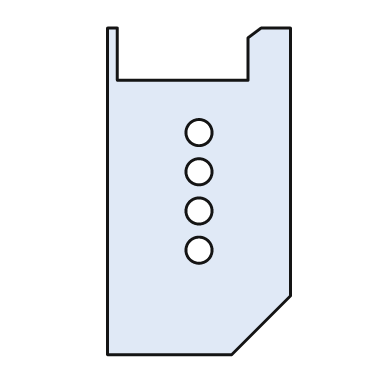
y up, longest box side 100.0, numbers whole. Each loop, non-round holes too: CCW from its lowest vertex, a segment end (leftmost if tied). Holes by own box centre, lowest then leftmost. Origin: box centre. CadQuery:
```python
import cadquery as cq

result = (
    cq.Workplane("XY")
    .moveTo(-28.0, -50.0)
    .lineTo(10.0, -50.0)
    .lineTo(28.0, -32.0)
    .lineTo(28.0, 50.0)
    .lineTo(19.0, 50.0)
    .lineTo(15.0, 47.0)
    .lineTo(15.0, 34.0)
    .lineTo(-25.0, 34.0)
    .lineTo(-25.0, 50.0)
    .lineTo(-28.0, 50.0)
    .close()
    .moveTo(0.0, -18.0)
    .circle(4.0)
    .moveTo(0.0, -6.0)
    .circle(4.0)
    .moveTo(0.0, 6.0)
    .circle(4.0)
    .moveTo(0.0, 18.0)
    .circle(4.0)
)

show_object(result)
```